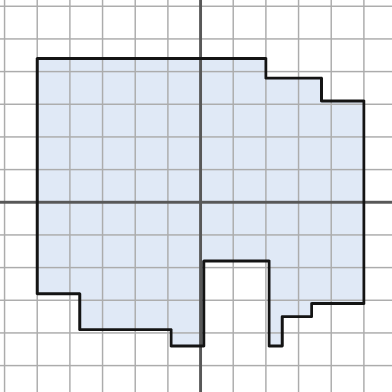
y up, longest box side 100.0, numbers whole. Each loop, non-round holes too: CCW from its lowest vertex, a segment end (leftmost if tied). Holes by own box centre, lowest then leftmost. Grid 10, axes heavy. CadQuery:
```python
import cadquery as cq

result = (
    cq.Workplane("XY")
    .moveTo(-9.0, -44.0)
    .lineTo(1.0, -44.0)
    .lineTo(1.0, -18.0)
    .lineTo(21.0, -18.0)
    .lineTo(21.0, -44.0)
    .lineTo(25.0, -44.0)
    .lineTo(25.0, -35.0)
    .lineTo(34.0, -35.0)
    .lineTo(34.0, -31.0)
    .lineTo(50.0, -31.0)
    .lineTo(50.0, 31.0)
    .lineTo(37.0, 31.0)
    .lineTo(37.0, 38.0)
    .lineTo(20.0, 38.0)
    .lineTo(20.0, 44.0)
    .lineTo(-50.0, 44.0)
    .lineTo(-50.0, -28.0)
    .lineTo(-37.0, -28.0)
    .lineTo(-37.0, -39.0)
    .lineTo(-9.0, -39.0)
    .close()
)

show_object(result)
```